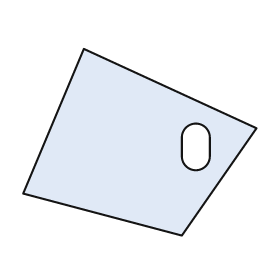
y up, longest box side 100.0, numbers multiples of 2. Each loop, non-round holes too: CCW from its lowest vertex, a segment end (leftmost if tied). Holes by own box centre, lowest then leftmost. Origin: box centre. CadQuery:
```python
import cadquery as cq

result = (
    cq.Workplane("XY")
    .moveTo(18.0, -40.0)
    .lineTo(50.0, 6.0)
    .lineTo(-24.0, 40.0)
    .lineTo(-50.0, -22.0)
    .close()
    .moveTo(18.0, -6.0)
    .threePointArc((24.0, -12.0), (30.0, -6.0))
    .lineTo(30.0, 2.0)
    .threePointArc((24.0, 8.0), (18.0, 2.0))
    .close()
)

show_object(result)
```